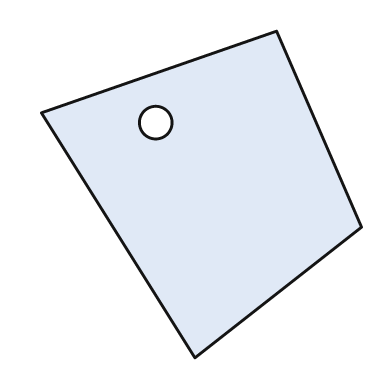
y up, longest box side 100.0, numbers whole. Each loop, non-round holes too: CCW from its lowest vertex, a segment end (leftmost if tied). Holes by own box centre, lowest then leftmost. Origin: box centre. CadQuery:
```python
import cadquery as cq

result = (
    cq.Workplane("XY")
    .moveTo(-2.0, -50.0)
    .lineTo(49.0, -10.0)
    .lineTo(23.0, 50.0)
    .lineTo(-49.0, 25.0)
    .close()
    .moveTo(-14.0, 22.0)
    .circle(5.0)
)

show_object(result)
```